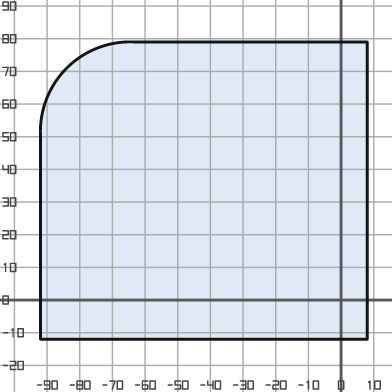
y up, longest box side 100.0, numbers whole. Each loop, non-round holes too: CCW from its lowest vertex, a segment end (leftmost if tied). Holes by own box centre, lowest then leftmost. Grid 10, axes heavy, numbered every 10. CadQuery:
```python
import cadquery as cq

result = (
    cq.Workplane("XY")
    .moveTo(-92.0, -12.0)
    .lineTo(8.0, -12.0)
    .lineTo(8.0, 79.0)
    .lineTo(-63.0, 79.0)
    .threePointArc((-84.0, 71.0), (-92.0, 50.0))
    .close()
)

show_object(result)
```